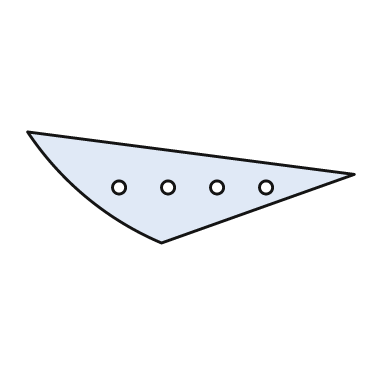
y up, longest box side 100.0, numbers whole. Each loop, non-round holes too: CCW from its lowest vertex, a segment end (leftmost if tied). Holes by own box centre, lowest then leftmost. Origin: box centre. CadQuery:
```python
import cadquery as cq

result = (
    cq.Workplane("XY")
    .moveTo(-9.0, -17.0)
    .lineTo(50.0, 4.0)
    .lineTo(-50.0, 17.0)
    .threePointArc((-32.0, -3.0), (-9.0, -17.0))
    .close()
    .moveTo(-22.0, 0.0)
    .circle(2.0)
    .moveTo(-7.0, 0.0)
    .circle(2.0)
    .moveTo(8.0, 0.0)
    .circle(2.0)
    .moveTo(23.0, 0.0)
    .circle(2.0)
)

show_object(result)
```